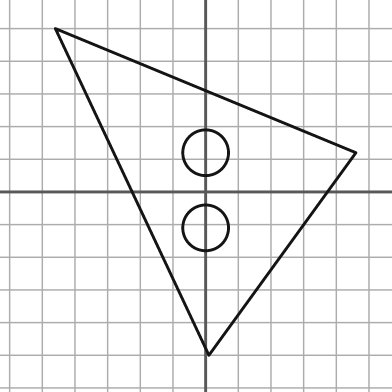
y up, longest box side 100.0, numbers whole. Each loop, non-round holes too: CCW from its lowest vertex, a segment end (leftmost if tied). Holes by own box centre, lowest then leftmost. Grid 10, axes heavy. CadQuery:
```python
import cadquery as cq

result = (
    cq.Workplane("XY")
    .moveTo(1.0, -50.0)
    .lineTo(46.0, 12.0)
    .lineTo(-46.0, 50.0)
    .close()
    .moveTo(0.0, -11.0)
    .circle(7.0)
    .moveTo(0.0, 12.0)
    .circle(7.0)
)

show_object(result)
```